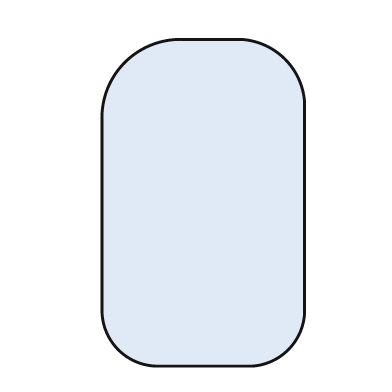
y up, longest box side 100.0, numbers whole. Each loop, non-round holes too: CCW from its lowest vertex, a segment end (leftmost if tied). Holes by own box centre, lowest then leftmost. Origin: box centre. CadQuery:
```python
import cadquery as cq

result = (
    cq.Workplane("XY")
    .moveTo(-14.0, -50.0)
    .lineTo(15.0, -50.0)
    .threePointArc((26.0, -45.0), (31.0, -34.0))
    .lineTo(31.0, 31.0)
    .threePointArc((25.0, 44.0), (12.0, 50.0))
    .lineTo(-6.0, 50.0)
    .threePointArc((-24.0, 43.0), (-31.0, 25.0))
    .lineTo(-31.0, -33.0)
    .threePointArc((-26.0, -45.0), (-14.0, -50.0))
    .close()
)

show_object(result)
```